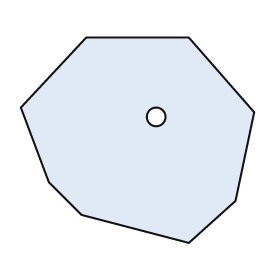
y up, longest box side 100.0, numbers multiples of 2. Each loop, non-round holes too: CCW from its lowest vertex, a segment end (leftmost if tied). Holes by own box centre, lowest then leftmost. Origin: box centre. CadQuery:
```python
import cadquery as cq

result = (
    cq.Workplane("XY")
    .moveTo(22.0, -44.0)
    .lineTo(42.0, -26.0)
    .lineTo(50.0, 12.0)
    .lineTo(22.0, 44.0)
    .lineTo(-22.0, 44.0)
    .lineTo(-50.0, 14.0)
    .lineTo(-38.0, -18.0)
    .lineTo(-24.0, -32.0)
    .close()
    .moveTo(8.0, 10.0)
    .circle(4.0)
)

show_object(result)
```